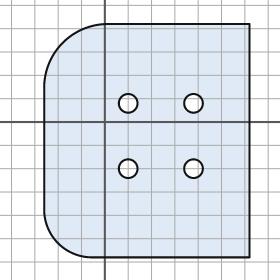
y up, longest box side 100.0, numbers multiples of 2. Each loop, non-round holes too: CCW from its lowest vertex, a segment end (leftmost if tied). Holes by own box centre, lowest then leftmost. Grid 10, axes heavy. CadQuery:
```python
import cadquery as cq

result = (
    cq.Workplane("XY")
    .moveTo(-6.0, -58.0)
    .lineTo(62.0, -58.0)
    .lineTo(62.0, 42.0)
    .lineTo(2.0, 42.0)
    .threePointArc((-18.0, 34.0), (-26.0, 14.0))
    .lineTo(-26.0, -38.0)
    .threePointArc((-20.0, -52.0), (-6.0, -58.0))
    .close()
    .moveTo(10.0, -20.0)
    .circle(4.0)
    .moveTo(38.0, -20.0)
    .circle(4.0)
    .moveTo(10.0, 8.0)
    .circle(4.0)
    .moveTo(38.0, 8.0)
    .circle(4.0)
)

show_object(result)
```